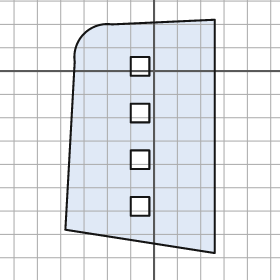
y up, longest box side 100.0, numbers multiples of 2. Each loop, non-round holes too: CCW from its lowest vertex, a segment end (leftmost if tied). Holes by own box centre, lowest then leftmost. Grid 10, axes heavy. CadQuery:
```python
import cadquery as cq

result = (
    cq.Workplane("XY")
    .moveTo(26.0, -78.0)
    .lineTo(26.0, 22.0)
    .lineTo(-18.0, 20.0)
    .threePointArc((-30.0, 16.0), (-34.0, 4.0))
    .lineTo(-38.0, -68.0)
    .close()
    .moveTo(-10.0, -62.0)
    .lineTo(-2.0, -62.0)
    .lineTo(-2.0, -54.0)
    .lineTo(-10.0, -54.0)
    .close()
    .moveTo(-10.0, -42.0)
    .lineTo(-2.0, -42.0)
    .lineTo(-2.0, -34.0)
    .lineTo(-10.0, -34.0)
    .close()
    .moveTo(-10.0, -22.0)
    .lineTo(-2.0, -22.0)
    .lineTo(-2.0, -14.0)
    .lineTo(-10.0, -14.0)
    .close()
    .moveTo(-10.0, -2.0)
    .lineTo(-2.0, -2.0)
    .lineTo(-2.0, 6.0)
    .lineTo(-10.0, 6.0)
    .close()
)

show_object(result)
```